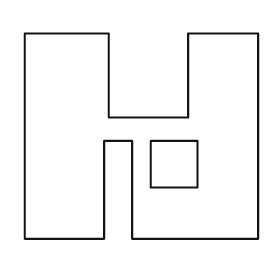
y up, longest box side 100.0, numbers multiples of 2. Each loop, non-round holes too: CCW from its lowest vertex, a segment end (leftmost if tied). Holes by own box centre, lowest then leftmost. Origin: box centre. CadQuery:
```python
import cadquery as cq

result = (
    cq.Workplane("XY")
    .moveTo(-50.0, -44.0)
    .lineTo(-16.0, -44.0)
    .lineTo(-16.0, -2.0)
    .lineTo(-4.0, -2.0)
    .lineTo(-4.0, -44.0)
    .lineTo(50.0, -44.0)
    .lineTo(50.0, 44.0)
    .lineTo(20.0, 44.0)
    .lineTo(20.0, 8.0)
    .lineTo(-14.0, 8.0)
    .lineTo(-14.0, 44.0)
    .lineTo(-50.0, 44.0)
    .close()
    .moveTo(4.0, -22.0)
    .lineTo(24.0, -22.0)
    .lineTo(24.0, -2.0)
    .lineTo(4.0, -2.0)
    .close()
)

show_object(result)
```